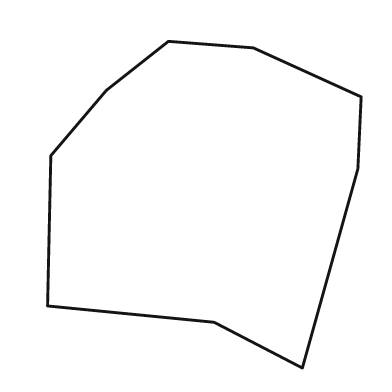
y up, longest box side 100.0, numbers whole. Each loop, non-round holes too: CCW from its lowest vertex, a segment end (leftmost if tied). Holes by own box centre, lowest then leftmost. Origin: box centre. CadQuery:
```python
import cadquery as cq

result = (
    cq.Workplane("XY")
    .moveTo(30.0, -50.0)
    .lineTo(47.0, 11.0)
    .lineTo(48.0, 33.0)
    .lineTo(15.0, 48.0)
    .lineTo(-11.0, 50.0)
    .lineTo(-30.0, 35.0)
    .lineTo(-47.0, 15.0)
    .lineTo(-48.0, -31.0)
    .lineTo(3.0, -36.0)
    .close()
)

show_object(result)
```